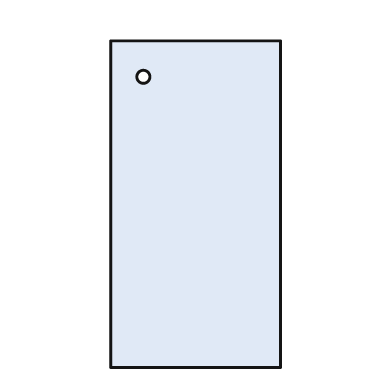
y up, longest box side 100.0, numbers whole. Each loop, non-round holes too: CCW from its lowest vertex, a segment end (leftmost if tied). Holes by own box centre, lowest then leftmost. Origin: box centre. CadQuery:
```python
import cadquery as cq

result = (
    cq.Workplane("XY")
    .moveTo(-26.0, -50.0)
    .lineTo(26.0, -50.0)
    .lineTo(26.0, 50.0)
    .lineTo(-26.0, 50.0)
    .close()
    .moveTo(-16.0, 39.0)
    .circle(2.0)
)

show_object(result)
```